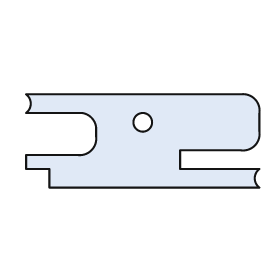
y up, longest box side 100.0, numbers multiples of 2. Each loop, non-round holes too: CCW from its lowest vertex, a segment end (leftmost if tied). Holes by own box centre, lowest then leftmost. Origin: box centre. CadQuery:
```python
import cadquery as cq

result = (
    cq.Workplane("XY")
    .moveTo(-40.0, -20.0)
    .lineTo(50.0, -20.0)
    .threePointArc((48.0, -16.0), (50.0, -12.0))
    .lineTo(16.0, -12.0)
    .lineTo(16.0, -4.0)
    .lineTo(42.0, -4.0)
    .threePointArc((48.0, -2.0), (50.0, 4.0))
    .lineTo(50.0, 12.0)
    .threePointArc((48.0, 18.0), (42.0, 20.0))
    .lineTo(-50.0, 20.0)
    .threePointArc((-48.0, 16.0), (-50.0, 12.0))
    .lineTo(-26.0, 12.0)
    .threePointArc((-22.0, 10.0), (-20.0, 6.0))
    .lineTo(-20.0, 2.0)
    .threePointArc((-22.0, -4.0), (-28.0, -6.0))
    .lineTo(-50.0, -6.0)
    .lineTo(-50.0, -12.0)
    .lineTo(-40.0, -12.0)
    .close()
    .moveTo(0.0, 8.0)
    .circle(4.0)
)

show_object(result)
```